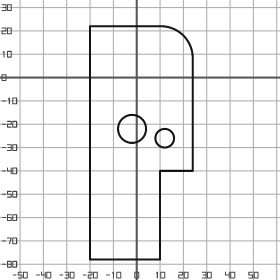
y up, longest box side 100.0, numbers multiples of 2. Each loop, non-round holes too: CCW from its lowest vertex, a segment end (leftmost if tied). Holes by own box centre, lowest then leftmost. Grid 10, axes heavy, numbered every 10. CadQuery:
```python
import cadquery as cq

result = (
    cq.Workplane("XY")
    .moveTo(-20.0, -78.0)
    .lineTo(10.0, -78.0)
    .lineTo(10.0, -40.0)
    .lineTo(24.0, -40.0)
    .lineTo(24.0, 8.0)
    .threePointArc((20.0, 18.0), (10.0, 22.0))
    .lineTo(-20.0, 22.0)
    .close()
    .moveTo(12.0, -26.0)
    .circle(4.0)
    .moveTo(-2.0, -22.0)
    .circle(6.0)
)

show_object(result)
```